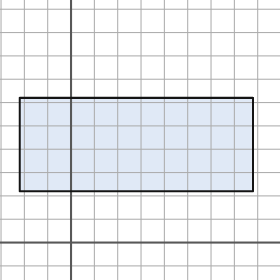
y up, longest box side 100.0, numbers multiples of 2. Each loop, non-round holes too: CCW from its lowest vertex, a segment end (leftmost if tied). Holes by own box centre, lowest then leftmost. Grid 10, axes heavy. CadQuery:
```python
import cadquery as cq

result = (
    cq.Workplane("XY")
    .moveTo(-22.0, 22.0)
    .lineTo(78.0, 22.0)
    .lineTo(78.0, 62.0)
    .lineTo(-22.0, 62.0)
    .close()
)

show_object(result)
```